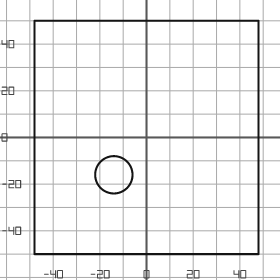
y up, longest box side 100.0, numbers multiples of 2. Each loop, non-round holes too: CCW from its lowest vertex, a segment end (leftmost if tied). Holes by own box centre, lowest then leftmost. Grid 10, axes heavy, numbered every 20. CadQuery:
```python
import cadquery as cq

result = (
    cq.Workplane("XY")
    .moveTo(-48.0, -50.0)
    .lineTo(48.0, -50.0)
    .lineTo(48.0, 50.0)
    .lineTo(-48.0, 50.0)
    .close()
    .moveTo(-14.0, -16.0)
    .circle(8.0)
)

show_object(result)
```